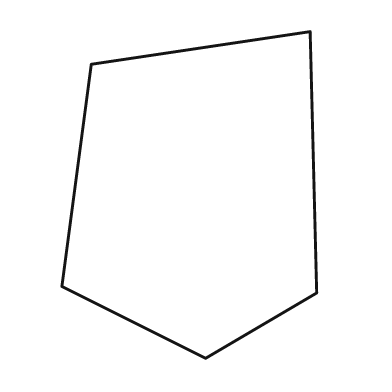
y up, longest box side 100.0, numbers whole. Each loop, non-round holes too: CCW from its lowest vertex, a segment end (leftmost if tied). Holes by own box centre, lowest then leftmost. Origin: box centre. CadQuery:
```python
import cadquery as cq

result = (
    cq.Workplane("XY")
    .moveTo(5.0, -50.0)
    .lineTo(39.0, -30.0)
    .lineTo(37.0, 50.0)
    .lineTo(-30.0, 40.0)
    .lineTo(-39.0, -28.0)
    .close()
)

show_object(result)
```